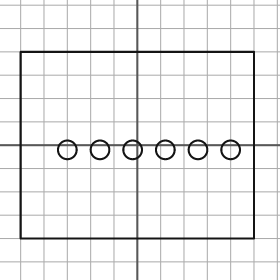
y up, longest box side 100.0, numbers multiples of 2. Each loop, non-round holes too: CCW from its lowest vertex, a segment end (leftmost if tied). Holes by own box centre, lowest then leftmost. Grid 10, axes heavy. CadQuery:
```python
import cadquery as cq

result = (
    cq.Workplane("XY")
    .moveTo(-50.0, -40.0)
    .lineTo(50.0, -40.0)
    .lineTo(50.0, 40.0)
    .lineTo(-50.0, 40.0)
    .close()
    .moveTo(-30.0, -2.0)
    .circle(4.0)
    .moveTo(-16.0, -2.0)
    .circle(4.0)
    .moveTo(-2.0, -2.0)
    .circle(4.0)
    .moveTo(12.0, -2.0)
    .circle(4.0)
    .moveTo(26.0, -2.0)
    .circle(4.0)
    .moveTo(40.0, -2.0)
    .circle(4.0)
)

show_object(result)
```